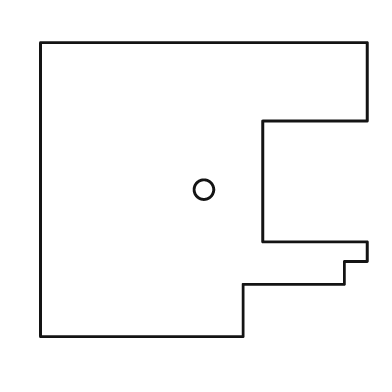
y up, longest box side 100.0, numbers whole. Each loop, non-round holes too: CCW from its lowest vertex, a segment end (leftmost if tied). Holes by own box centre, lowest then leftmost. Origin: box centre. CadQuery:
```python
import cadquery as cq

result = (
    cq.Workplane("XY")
    .moveTo(-50.0, -45.0)
    .lineTo(12.0, -45.0)
    .lineTo(12.0, -29.0)
    .lineTo(43.0, -29.0)
    .lineTo(43.0, -22.0)
    .lineTo(50.0, -22.0)
    .lineTo(50.0, -16.0)
    .lineTo(18.0, -16.0)
    .lineTo(18.0, 21.0)
    .lineTo(50.0, 21.0)
    .lineTo(50.0, 45.0)
    .lineTo(-50.0, 45.0)
    .close()
    .moveTo(0.0, 0.0)
    .circle(3.0)
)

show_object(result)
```